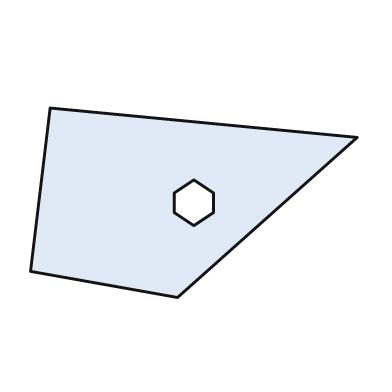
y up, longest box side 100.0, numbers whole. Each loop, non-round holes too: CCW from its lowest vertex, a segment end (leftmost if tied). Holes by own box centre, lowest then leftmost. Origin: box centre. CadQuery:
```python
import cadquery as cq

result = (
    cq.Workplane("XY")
    .moveTo(-5.0, -29.0)
    .lineTo(50.0, 20.0)
    .lineTo(-44.0, 29.0)
    .lineTo(-50.0, -21.0)
    .close()
    .moveTo(0.0, -7.0)
    .lineTo(6.0, -3.0)
    .lineTo(6.0, 3.0)
    .lineTo(0.0, 7.0)
    .lineTo(-6.0, 3.0)
    .lineTo(-6.0, -3.0)
    .close()
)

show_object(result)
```